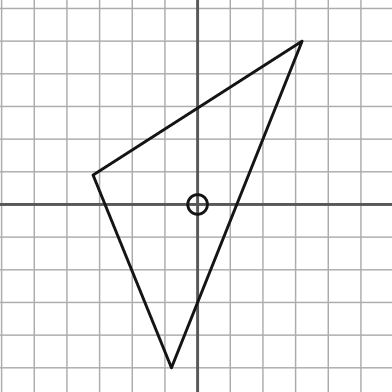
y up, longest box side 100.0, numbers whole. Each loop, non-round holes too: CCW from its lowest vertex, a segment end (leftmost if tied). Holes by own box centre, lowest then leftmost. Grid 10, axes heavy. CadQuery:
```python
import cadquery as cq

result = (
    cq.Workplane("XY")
    .moveTo(-8.0, -50.0)
    .lineTo(32.0, 50.0)
    .lineTo(-32.0, 9.0)
    .close()
    .moveTo(0.0, 0.0)
    .circle(3.0)
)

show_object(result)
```